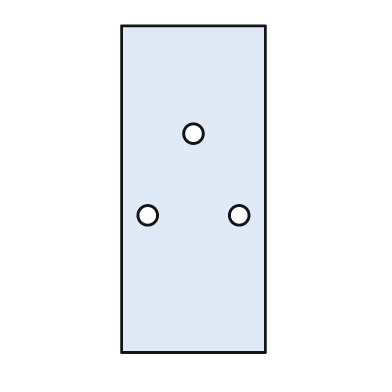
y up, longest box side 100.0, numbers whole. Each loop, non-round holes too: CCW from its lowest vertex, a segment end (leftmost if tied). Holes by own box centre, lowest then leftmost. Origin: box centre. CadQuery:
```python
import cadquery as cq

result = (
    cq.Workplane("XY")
    .moveTo(-22.0, -50.0)
    .lineTo(22.0, -50.0)
    .lineTo(22.0, 50.0)
    .lineTo(-22.0, 50.0)
    .close()
    .moveTo(-14.0, -8.0)
    .circle(3.0)
    .moveTo(14.0, -8.0)
    .circle(3.0)
    .moveTo(0.0, 17.0)
    .circle(3.0)
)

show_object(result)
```